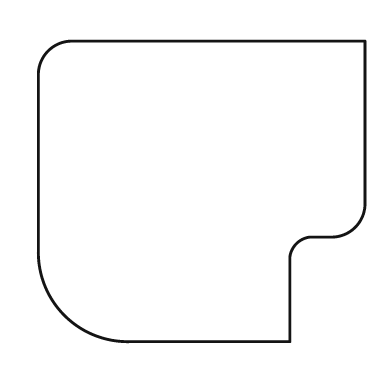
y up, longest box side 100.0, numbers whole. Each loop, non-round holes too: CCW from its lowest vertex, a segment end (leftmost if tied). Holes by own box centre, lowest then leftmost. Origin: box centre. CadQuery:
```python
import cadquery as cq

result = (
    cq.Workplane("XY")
    .moveTo(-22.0, -46.0)
    .lineTo(27.0, -46.0)
    .lineTo(27.0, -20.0)
    .threePointArc((29.0, -16.0), (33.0, -14.0))
    .lineTo(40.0, -14.0)
    .threePointArc((47.0, -11.0), (50.0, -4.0))
    .lineTo(50.0, 46.0)
    .lineTo(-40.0, 46.0)
    .threePointArc((-47.0, 43.0), (-50.0, 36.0))
    .lineTo(-50.0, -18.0)
    .threePointArc((-42.0, -38.0), (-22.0, -46.0))
    .close()
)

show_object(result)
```